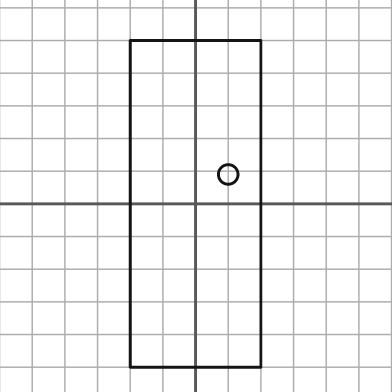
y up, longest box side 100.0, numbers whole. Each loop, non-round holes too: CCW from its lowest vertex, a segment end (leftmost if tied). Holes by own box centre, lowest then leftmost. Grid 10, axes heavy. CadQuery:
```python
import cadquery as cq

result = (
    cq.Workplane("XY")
    .moveTo(-20.0, -50.0)
    .lineTo(20.0, -50.0)
    .lineTo(20.0, 50.0)
    .lineTo(-20.0, 50.0)
    .close()
    .moveTo(10.0, 9.0)
    .circle(3.0)
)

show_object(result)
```